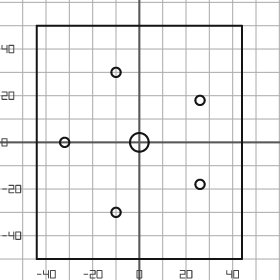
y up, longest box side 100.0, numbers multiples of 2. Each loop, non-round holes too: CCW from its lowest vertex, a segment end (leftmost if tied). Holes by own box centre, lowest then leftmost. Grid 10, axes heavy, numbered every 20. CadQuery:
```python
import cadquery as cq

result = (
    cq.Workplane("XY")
    .moveTo(-44.0, -50.0)
    .lineTo(44.0, -50.0)
    .lineTo(44.0, 50.0)
    .lineTo(-44.0, 50.0)
    .close()
    .moveTo(-10.0, -30.0)
    .circle(2.0)
    .moveTo(26.0, -18.0)
    .circle(2.0)
    .moveTo(-32.0, 0.0)
    .circle(2.0)
    .moveTo(0.0, 0.0)
    .circle(4.0)
    .moveTo(26.0, 18.0)
    .circle(2.0)
    .moveTo(-10.0, 30.0)
    .circle(2.0)
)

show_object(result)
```